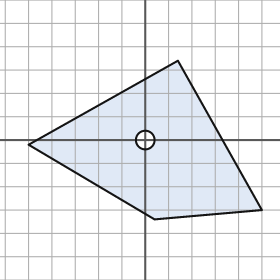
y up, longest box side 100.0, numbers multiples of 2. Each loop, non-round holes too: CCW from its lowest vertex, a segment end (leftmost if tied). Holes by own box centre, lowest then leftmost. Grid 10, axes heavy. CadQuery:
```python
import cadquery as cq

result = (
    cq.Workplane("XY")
    .moveTo(4.0, -34.0)
    .lineTo(50.0, -30.0)
    .lineTo(14.0, 34.0)
    .lineTo(-50.0, -2.0)
    .close()
    .moveTo(0.0, 0.0)
    .circle(4.0)
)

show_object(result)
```